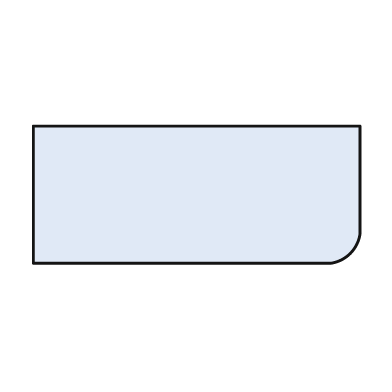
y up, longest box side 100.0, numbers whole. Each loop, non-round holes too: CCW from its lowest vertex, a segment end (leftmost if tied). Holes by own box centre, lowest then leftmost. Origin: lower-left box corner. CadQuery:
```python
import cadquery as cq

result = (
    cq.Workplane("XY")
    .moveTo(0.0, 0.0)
    .lineTo(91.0, 0.0)
    .threePointArc((97.0, 3.0), (100.0, 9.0))
    .lineTo(100.0, 42.0)
    .lineTo(0.0, 42.0)
    .close()
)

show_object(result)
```